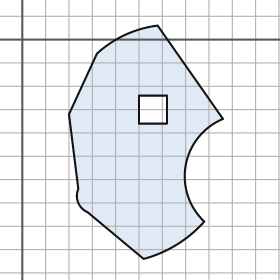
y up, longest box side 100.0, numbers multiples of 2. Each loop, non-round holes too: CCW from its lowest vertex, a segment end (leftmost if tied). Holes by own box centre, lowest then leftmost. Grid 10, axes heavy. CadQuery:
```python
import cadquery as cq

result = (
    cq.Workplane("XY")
    .moveTo(52.0, -94.0)
    .threePointArc((66.0, -88.0), (78.0, -78.0))
    .threePointArc((70.0, -54.0), (86.0, -34.0))
    .lineTo(58.0, 6.0)
    .threePointArc((44.0, 2.0), (32.0, -6.0))
    .lineTo(20.0, -32.0)
    .lineTo(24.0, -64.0)
    .threePointArc((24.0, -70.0), (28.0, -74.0))
    .close()
    .moveTo(50.0, -36.0)
    .lineTo(62.0, -36.0)
    .lineTo(62.0, -24.0)
    .lineTo(50.0, -24.0)
    .close()
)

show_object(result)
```